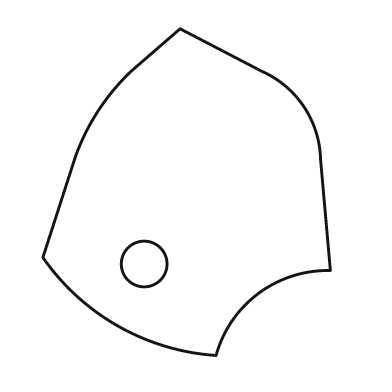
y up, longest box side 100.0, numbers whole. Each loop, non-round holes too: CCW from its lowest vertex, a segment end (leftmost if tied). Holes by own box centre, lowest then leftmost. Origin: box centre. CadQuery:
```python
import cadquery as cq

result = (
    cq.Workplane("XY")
    .moveTo(9.0, -50.0)
    .threePointArc((22.0, -31.0), (44.0, -24.0))
    .lineTo(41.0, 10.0)
    .threePointArc((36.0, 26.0), (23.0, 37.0))
    .lineTo(-2.0, 50.0)
    .lineTo(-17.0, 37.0)
    .threePointArc((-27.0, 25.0), (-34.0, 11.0))
    .lineTo(-44.0, -20.0)
    .threePointArc((-21.0, -41.0), (9.0, -50.0))
    .close()
    .moveTo(-13.0, -22.0)
    .circle(7.0)
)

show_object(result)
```